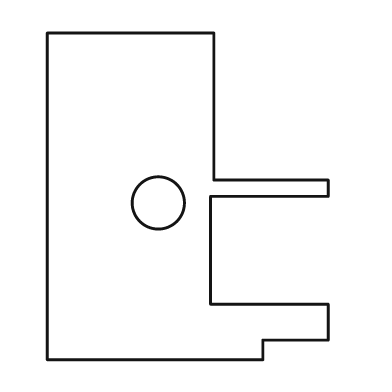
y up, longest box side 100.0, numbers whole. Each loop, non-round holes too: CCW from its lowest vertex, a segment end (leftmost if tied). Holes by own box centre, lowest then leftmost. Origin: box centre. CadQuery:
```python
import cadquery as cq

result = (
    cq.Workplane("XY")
    .moveTo(-43.0, -50.0)
    .lineTo(23.0, -50.0)
    .lineTo(23.0, -44.0)
    .lineTo(43.0, -44.0)
    .lineTo(43.0, -33.0)
    .lineTo(7.0, -33.0)
    .lineTo(7.0, 0.0)
    .lineTo(43.0, 0.0)
    .lineTo(43.0, 5.0)
    .lineTo(8.0, 5.0)
    .lineTo(8.0, 50.0)
    .lineTo(-43.0, 50.0)
    .close()
    .moveTo(-9.0, -2.0)
    .circle(8.0)
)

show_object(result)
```